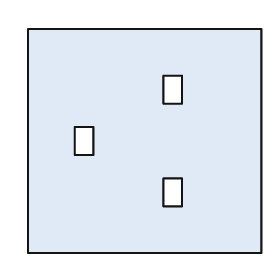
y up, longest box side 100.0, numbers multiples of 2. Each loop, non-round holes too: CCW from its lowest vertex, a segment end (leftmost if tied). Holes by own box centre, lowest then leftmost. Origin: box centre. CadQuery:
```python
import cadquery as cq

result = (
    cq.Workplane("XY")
    .moveTo(-50.0, -48.0)
    .lineTo(50.0, -48.0)
    .lineTo(50.0, 48.0)
    .lineTo(-50.0, 48.0)
    .close()
    .moveTo(8.0, -28.0)
    .lineTo(16.0, -28.0)
    .lineTo(16.0, -16.0)
    .lineTo(8.0, -16.0)
    .close()
    .moveTo(-30.0, -6.0)
    .lineTo(-22.0, -6.0)
    .lineTo(-22.0, 6.0)
    .lineTo(-30.0, 6.0)
    .close()
    .moveTo(8.0, 16.0)
    .lineTo(16.0, 16.0)
    .lineTo(16.0, 28.0)
    .lineTo(8.0, 28.0)
    .close()
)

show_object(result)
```